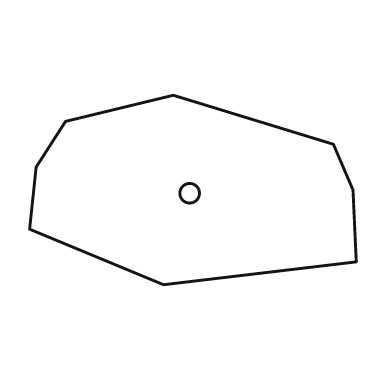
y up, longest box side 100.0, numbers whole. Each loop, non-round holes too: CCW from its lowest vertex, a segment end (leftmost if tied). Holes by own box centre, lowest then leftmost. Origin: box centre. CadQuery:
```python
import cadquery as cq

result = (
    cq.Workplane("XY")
    .moveTo(-9.0, -29.0)
    .lineTo(50.0, -22.0)
    .lineTo(49.0, 0.0)
    .lineTo(43.0, 14.0)
    .lineTo(-6.0, 29.0)
    .lineTo(-39.0, 21.0)
    .lineTo(-48.0, 7.0)
    .lineTo(-50.0, -12.0)
    .close()
    .moveTo(-1.0, -1.0)
    .circle(3.0)
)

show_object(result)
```